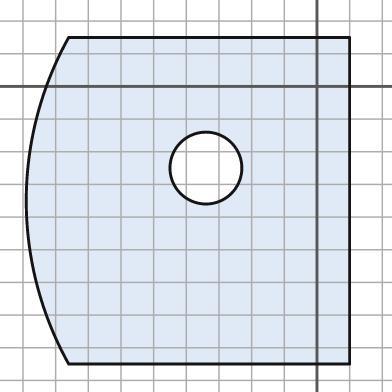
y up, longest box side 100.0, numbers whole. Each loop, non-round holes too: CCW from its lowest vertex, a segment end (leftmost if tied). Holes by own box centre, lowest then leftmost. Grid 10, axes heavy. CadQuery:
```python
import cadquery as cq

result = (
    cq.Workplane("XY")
    .moveTo(-76.0, -85.0)
    .lineTo(10.0, -85.0)
    .lineTo(10.0, 15.0)
    .lineTo(-76.0, 15.0)
    .threePointArc((-89.0, -35.0), (-76.0, -85.0))
    .close()
    .moveTo(-34.0, -25.0)
    .circle(11.0)
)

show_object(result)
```